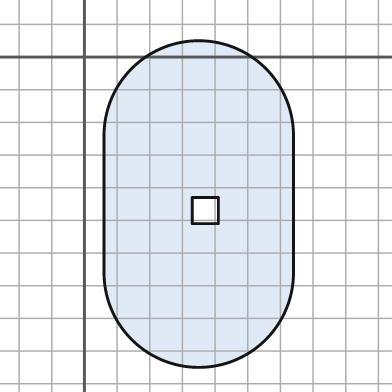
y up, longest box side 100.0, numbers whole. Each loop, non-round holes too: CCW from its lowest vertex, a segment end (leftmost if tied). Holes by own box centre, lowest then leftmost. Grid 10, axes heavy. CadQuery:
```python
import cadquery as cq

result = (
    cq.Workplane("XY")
    .moveTo(6.0, -66.0)
    .threePointArc((35.0, -95.0), (64.0, -66.0))
    .lineTo(64.0, -24.0)
    .threePointArc((35.0, 5.0), (6.0, -24.0))
    .close()
    .moveTo(33.0, -51.0)
    .lineTo(41.0, -51.0)
    .lineTo(41.0, -43.0)
    .lineTo(33.0, -43.0)
    .close()
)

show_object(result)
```